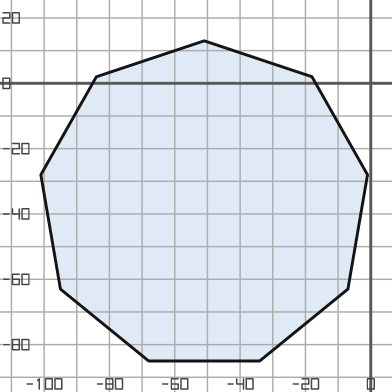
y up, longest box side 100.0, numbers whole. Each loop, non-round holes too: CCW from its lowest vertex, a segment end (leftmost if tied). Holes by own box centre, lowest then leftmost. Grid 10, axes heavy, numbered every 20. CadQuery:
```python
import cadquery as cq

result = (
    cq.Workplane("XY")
    .moveTo(-68.0, -85.0)
    .lineTo(-34.0, -85.0)
    .lineTo(-7.0, -63.0)
    .lineTo(-1.0, -28.0)
    .lineTo(-18.0, 2.0)
    .lineTo(-51.0, 13.0)
    .lineTo(-84.0, 2.0)
    .lineTo(-101.0, -28.0)
    .lineTo(-95.0, -63.0)
    .close()
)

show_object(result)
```